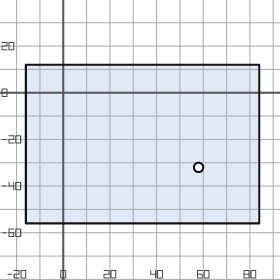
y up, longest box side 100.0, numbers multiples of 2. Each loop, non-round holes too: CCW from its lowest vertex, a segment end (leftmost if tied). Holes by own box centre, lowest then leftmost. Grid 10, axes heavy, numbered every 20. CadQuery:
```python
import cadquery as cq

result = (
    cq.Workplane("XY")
    .moveTo(-16.0, -56.0)
    .lineTo(84.0, -56.0)
    .lineTo(84.0, 12.0)
    .lineTo(-16.0, 12.0)
    .close()
    .moveTo(58.0, -32.0)
    .circle(2.0)
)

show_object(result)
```